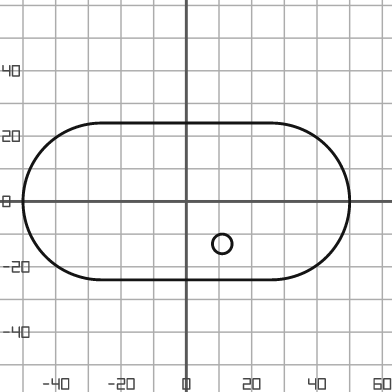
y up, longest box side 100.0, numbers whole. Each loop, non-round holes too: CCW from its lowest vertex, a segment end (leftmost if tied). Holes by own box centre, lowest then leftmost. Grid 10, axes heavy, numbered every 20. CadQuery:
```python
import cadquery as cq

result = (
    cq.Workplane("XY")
    .moveTo(-26.0, -24.0)
    .lineTo(26.0, -24.0)
    .threePointArc((50.0, 0.0), (26.0, 24.0))
    .lineTo(-26.0, 24.0)
    .threePointArc((-50.0, 0.0), (-26.0, -24.0))
    .close()
    .moveTo(11.0, -13.0)
    .circle(3.0)
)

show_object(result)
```